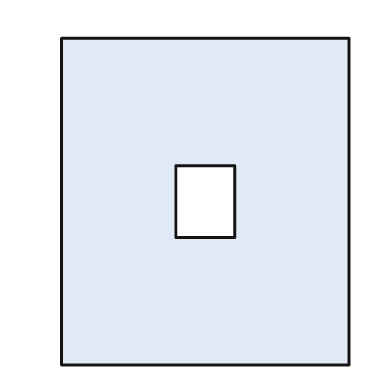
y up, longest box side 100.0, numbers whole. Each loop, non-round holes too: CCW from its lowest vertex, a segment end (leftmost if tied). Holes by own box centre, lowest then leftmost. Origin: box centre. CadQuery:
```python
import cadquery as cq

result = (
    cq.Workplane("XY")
    .moveTo(-44.0, -50.0)
    .lineTo(44.0, -50.0)
    .lineTo(44.0, 50.0)
    .lineTo(-44.0, 50.0)
    .close()
    .moveTo(-9.0, -11.0)
    .lineTo(9.0, -11.0)
    .lineTo(9.0, 11.0)
    .lineTo(-9.0, 11.0)
    .close()
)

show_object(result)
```